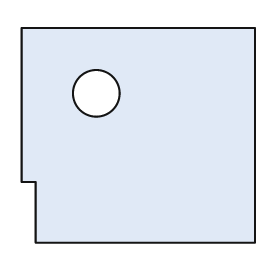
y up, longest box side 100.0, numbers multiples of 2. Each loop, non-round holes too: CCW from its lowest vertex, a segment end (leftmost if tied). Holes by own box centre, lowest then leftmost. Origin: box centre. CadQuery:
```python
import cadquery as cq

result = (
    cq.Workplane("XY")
    .moveTo(-44.0, -46.0)
    .lineTo(50.0, -46.0)
    .lineTo(50.0, 46.0)
    .lineTo(-50.0, 46.0)
    .lineTo(-50.0, -20.0)
    .lineTo(-44.0, -20.0)
    .close()
    .moveTo(-18.0, 18.0)
    .circle(10.0)
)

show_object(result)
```